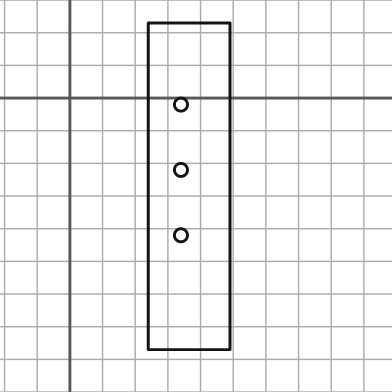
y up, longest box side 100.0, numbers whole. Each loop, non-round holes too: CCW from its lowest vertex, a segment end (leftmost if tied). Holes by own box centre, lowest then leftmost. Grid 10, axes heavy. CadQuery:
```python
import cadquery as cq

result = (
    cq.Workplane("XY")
    .moveTo(24.0, -77.0)
    .lineTo(49.0, -77.0)
    .lineTo(49.0, 23.0)
    .lineTo(24.0, 23.0)
    .close()
    .moveTo(34.0, -42.0)
    .circle(2.0)
    .moveTo(34.0, -22.0)
    .circle(2.0)
    .moveTo(34.0, -2.0)
    .circle(2.0)
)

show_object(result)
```